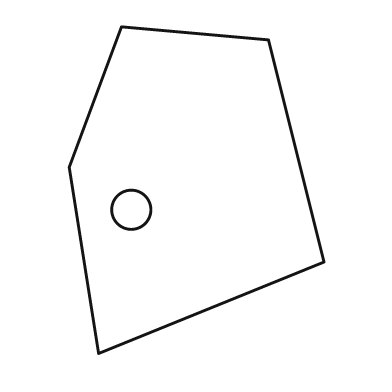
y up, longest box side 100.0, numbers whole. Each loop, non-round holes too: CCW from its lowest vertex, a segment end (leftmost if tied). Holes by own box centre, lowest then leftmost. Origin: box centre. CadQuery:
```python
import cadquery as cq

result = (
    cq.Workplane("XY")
    .moveTo(-30.0, -50.0)
    .lineTo(39.0, -22.0)
    .lineTo(22.0, 46.0)
    .lineTo(-23.0, 50.0)
    .lineTo(-39.0, 7.0)
    .close()
    .moveTo(-20.0, -6.0)
    .circle(6.0)
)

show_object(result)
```